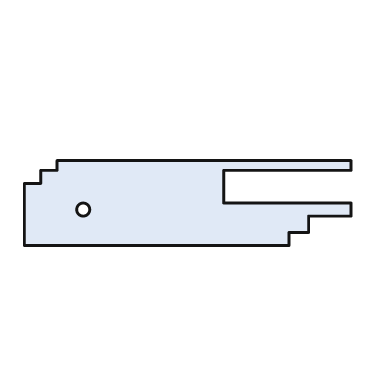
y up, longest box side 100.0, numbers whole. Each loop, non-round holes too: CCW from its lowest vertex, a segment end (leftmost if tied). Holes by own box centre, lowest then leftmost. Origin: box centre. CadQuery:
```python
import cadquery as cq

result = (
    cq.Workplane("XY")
    .moveTo(-50.0, -13.0)
    .lineTo(31.0, -13.0)
    .lineTo(31.0, -9.0)
    .lineTo(37.0, -9.0)
    .lineTo(37.0, -4.0)
    .lineTo(50.0, -4.0)
    .lineTo(50.0, 0.0)
    .lineTo(11.0, 0.0)
    .lineTo(11.0, 10.0)
    .lineTo(50.0, 10.0)
    .lineTo(50.0, 13.0)
    .lineTo(-40.0, 13.0)
    .lineTo(-40.0, 10.0)
    .lineTo(-45.0, 10.0)
    .lineTo(-45.0, 6.0)
    .lineTo(-50.0, 6.0)
    .close()
    .moveTo(-32.0, -2.0)
    .circle(2.0)
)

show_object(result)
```